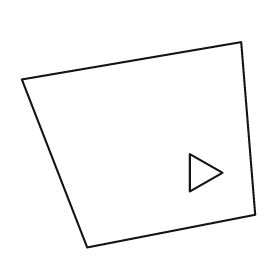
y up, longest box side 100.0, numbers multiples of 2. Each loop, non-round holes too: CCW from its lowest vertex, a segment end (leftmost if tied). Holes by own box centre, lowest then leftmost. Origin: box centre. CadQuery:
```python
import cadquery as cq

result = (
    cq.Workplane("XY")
    .moveTo(-22.0, -44.0)
    .lineTo(50.0, -30.0)
    .lineTo(44.0, 44.0)
    .lineTo(-50.0, 28.0)
    .close()
    .moveTo(22.0, -20.0)
    .lineTo(36.0, -12.0)
    .lineTo(22.0, -4.0)
    .close()
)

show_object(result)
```